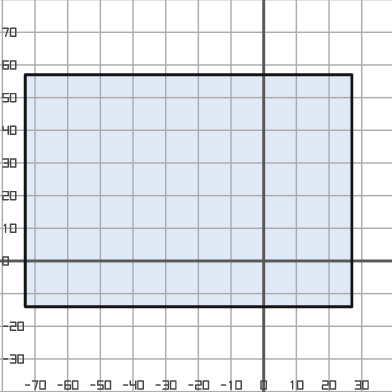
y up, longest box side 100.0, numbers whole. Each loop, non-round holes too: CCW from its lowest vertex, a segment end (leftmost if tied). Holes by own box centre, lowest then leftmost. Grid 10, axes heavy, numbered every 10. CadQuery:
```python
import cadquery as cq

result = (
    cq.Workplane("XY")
    .moveTo(-73.0, -14.0)
    .lineTo(27.0, -14.0)
    .lineTo(27.0, 57.0)
    .lineTo(-73.0, 57.0)
    .close()
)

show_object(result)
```